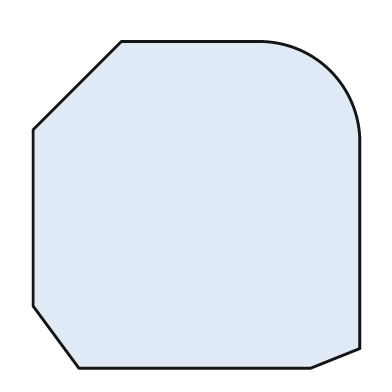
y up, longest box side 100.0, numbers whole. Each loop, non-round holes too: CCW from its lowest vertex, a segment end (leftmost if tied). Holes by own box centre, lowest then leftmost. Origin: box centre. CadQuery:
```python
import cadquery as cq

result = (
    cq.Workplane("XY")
    .moveTo(-36.0, -50.0)
    .lineTo(35.0, -50.0)
    .lineTo(50.0, -44.0)
    .lineTo(50.0, 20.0)
    .threePointArc((41.0, 41.0), (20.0, 50.0))
    .lineTo(-23.0, 50.0)
    .lineTo(-50.0, 23.0)
    .lineTo(-50.0, -31.0)
    .close()
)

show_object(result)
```